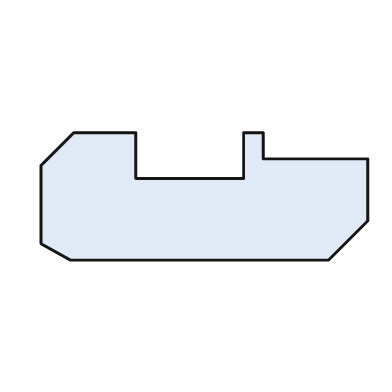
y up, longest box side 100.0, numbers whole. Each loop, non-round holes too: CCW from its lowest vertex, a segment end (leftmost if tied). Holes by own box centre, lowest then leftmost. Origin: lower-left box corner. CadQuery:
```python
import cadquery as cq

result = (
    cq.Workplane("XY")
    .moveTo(9.0, 0.0)
    .lineTo(88.0, 0.0)
    .lineTo(100.0, 12.0)
    .lineTo(100.0, 31.0)
    .lineTo(68.0, 31.0)
    .lineTo(68.0, 39.0)
    .lineTo(62.0, 39.0)
    .lineTo(62.0, 25.0)
    .lineTo(29.0, 25.0)
    .lineTo(29.0, 39.0)
    .lineTo(10.0, 39.0)
    .lineTo(0.0, 29.0)
    .lineTo(0.0, 5.0)
    .close()
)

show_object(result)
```